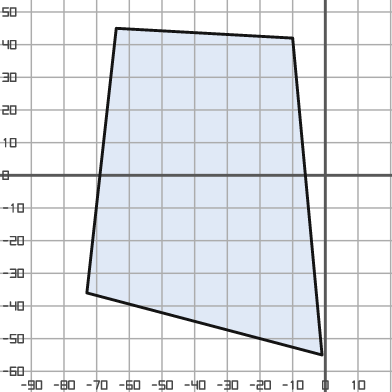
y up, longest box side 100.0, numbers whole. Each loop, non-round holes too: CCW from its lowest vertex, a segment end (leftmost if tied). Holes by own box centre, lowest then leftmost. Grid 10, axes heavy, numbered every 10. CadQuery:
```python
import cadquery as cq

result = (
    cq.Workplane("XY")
    .moveTo(-1.0, -55.0)
    .lineTo(-10.0, 42.0)
    .lineTo(-64.0, 45.0)
    .lineTo(-73.0, -36.0)
    .close()
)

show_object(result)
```